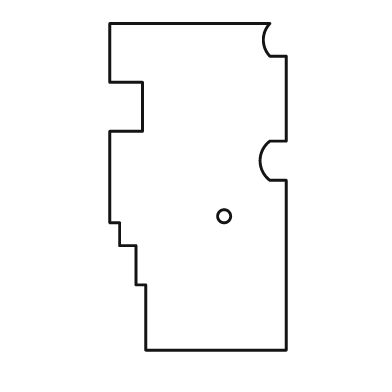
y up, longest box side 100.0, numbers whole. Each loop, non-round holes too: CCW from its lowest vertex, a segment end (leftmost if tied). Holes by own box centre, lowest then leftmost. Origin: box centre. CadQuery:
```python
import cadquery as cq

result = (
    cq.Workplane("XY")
    .moveTo(-16.0, -50.0)
    .lineTo(27.0, -50.0)
    .lineTo(27.0, 2.0)
    .lineTo(22.0, 2.0)
    .threePointArc((19.0, 8.0), (22.0, 14.0))
    .lineTo(27.0, 14.0)
    .lineTo(27.0, 40.0)
    .lineTo(22.0, 40.0)
    .threePointArc((20.0, 45.0), (22.0, 50.0))
    .lineTo(-27.0, 50.0)
    .lineTo(-27.0, 32.0)
    .lineTo(-17.0, 32.0)
    .lineTo(-17.0, 17.0)
    .lineTo(-27.0, 17.0)
    .lineTo(-27.0, -11.0)
    .lineTo(-24.0, -11.0)
    .lineTo(-24.0, -18.0)
    .lineTo(-19.0, -18.0)
    .lineTo(-19.0, -30.0)
    .lineTo(-16.0, -30.0)
    .close()
    .moveTo(8.0, -9.0)
    .circle(2.0)
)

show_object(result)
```